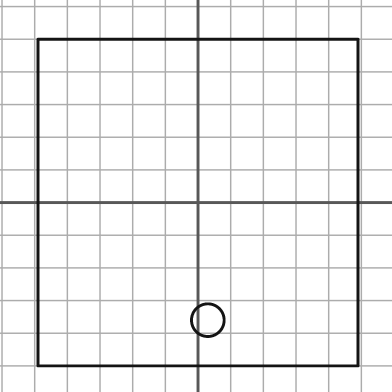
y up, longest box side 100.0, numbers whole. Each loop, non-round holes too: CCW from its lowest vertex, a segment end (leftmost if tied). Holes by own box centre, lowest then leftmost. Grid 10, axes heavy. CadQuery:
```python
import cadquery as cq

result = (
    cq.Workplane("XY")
    .moveTo(-49.0, -50.0)
    .lineTo(49.0, -50.0)
    .lineTo(49.0, 50.0)
    .lineTo(-49.0, 50.0)
    .close()
    .moveTo(3.0, -36.0)
    .circle(5.0)
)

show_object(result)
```